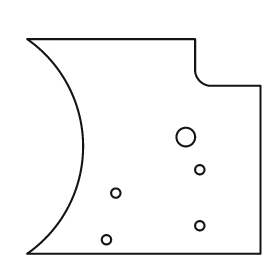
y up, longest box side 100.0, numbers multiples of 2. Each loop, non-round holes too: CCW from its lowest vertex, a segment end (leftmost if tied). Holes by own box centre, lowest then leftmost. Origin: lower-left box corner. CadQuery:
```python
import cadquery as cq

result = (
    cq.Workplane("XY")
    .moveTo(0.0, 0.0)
    .lineTo(100.0, 0.0)
    .lineTo(100.0, 72.0)
    .lineTo(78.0, 72.0)
    .threePointArc((74.0, 74.0), (72.0, 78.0))
    .lineTo(72.0, 92.0)
    .lineTo(0.0, 92.0)
    .threePointArc((24.0, 46.0), (0.0, 0.0))
    .close()
    .moveTo(34.0, 6.0)
    .circle(2.0)
    .moveTo(74.0, 12.0)
    .circle(2.0)
    .moveTo(38.0, 26.0)
    .circle(2.0)
    .moveTo(74.0, 36.0)
    .circle(2.0)
    .moveTo(68.0, 50.0)
    .circle(4.0)
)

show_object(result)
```